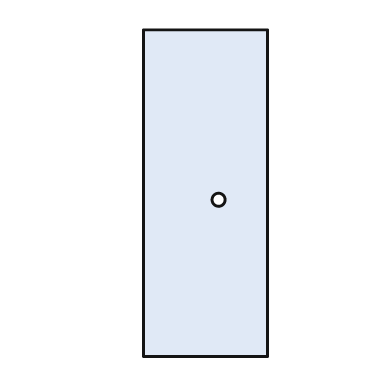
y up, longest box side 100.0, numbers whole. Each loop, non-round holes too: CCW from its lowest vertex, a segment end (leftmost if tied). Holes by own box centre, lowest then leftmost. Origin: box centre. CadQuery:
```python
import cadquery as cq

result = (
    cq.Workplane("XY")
    .moveTo(-19.0, -50.0)
    .lineTo(19.0, -50.0)
    .lineTo(19.0, 50.0)
    .lineTo(-19.0, 50.0)
    .close()
    .moveTo(4.0, -2.0)
    .circle(2.0)
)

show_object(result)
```